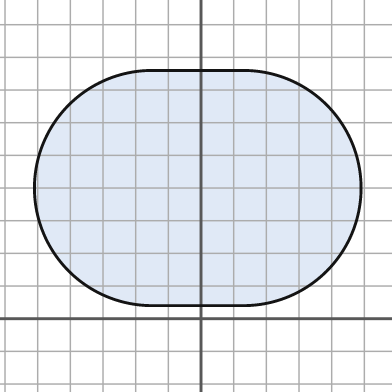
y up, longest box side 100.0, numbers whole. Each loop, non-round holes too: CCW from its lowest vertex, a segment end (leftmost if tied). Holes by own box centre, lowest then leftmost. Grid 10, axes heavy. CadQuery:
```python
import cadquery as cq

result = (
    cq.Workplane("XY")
    .moveTo(-15.0, 4.0)
    .lineTo(13.0, 4.0)
    .threePointArc((49.0, 40.0), (13.0, 76.0))
    .lineTo(-15.0, 76.0)
    .threePointArc((-51.0, 40.0), (-15.0, 4.0))
    .close()
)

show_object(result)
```